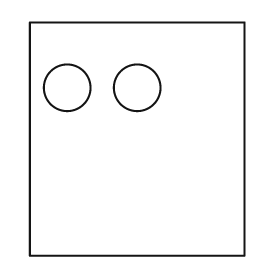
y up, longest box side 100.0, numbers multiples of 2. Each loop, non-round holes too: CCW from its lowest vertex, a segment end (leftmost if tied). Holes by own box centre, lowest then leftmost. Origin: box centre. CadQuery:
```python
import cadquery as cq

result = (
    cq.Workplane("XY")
    .moveTo(-46.0, -50.0)
    .lineTo(46.0, -50.0)
    .lineTo(46.0, 50.0)
    .lineTo(-46.0, 50.0)
    .close()
    .moveTo(-30.0, 22.0)
    .circle(10.0)
    .moveTo(0.0, 22.0)
    .circle(10.0)
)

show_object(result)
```